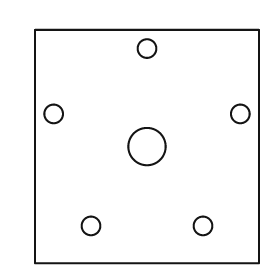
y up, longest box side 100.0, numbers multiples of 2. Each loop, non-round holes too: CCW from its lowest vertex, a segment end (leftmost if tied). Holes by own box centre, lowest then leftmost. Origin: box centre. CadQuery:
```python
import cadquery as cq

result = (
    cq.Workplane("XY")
    .moveTo(-48.0, -50.0)
    .lineTo(48.0, -50.0)
    .lineTo(48.0, 50.0)
    .lineTo(-48.0, 50.0)
    .close()
    .moveTo(-24.0, -34.0)
    .circle(4.0)
    .moveTo(24.0, -34.0)
    .circle(4.0)
    .moveTo(0.0, 0.0)
    .circle(8.0)
    .moveTo(-40.0, 14.0)
    .circle(4.0)
    .moveTo(40.0, 14.0)
    .circle(4.0)
    .moveTo(0.0, 42.0)
    .circle(4.0)
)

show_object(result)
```